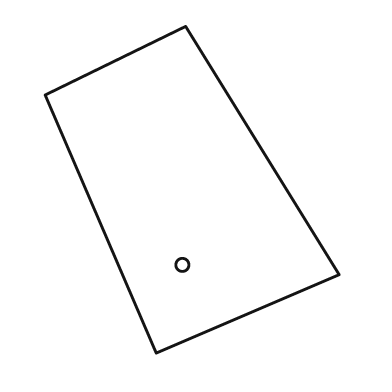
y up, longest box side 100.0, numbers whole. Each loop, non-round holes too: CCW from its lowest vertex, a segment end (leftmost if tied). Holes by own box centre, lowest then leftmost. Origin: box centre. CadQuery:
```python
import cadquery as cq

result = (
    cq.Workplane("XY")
    .moveTo(-11.0, -50.0)
    .lineTo(45.0, -26.0)
    .lineTo(-2.0, 50.0)
    .lineTo(-45.0, 29.0)
    .close()
    .moveTo(-3.0, -23.0)
    .circle(2.0)
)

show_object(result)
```